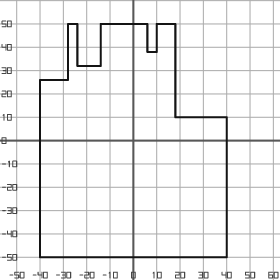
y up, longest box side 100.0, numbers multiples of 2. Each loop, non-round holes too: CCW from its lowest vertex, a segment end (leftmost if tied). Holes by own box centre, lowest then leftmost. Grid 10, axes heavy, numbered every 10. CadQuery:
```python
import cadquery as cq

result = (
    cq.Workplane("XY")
    .moveTo(-40.0, -50.0)
    .lineTo(40.0, -50.0)
    .lineTo(40.0, 10.0)
    .lineTo(18.0, 10.0)
    .lineTo(18.0, 50.0)
    .lineTo(10.0, 50.0)
    .lineTo(10.0, 38.0)
    .lineTo(6.0, 38.0)
    .lineTo(6.0, 50.0)
    .lineTo(-14.0, 50.0)
    .lineTo(-14.0, 32.0)
    .lineTo(-24.0, 32.0)
    .lineTo(-24.0, 50.0)
    .lineTo(-28.0, 50.0)
    .lineTo(-28.0, 26.0)
    .lineTo(-40.0, 26.0)
    .close()
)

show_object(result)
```